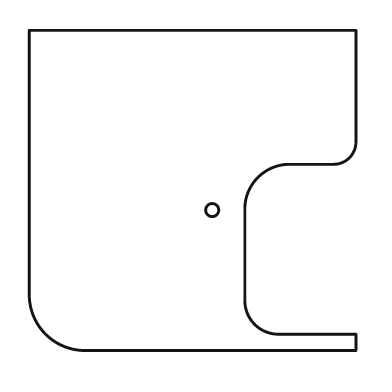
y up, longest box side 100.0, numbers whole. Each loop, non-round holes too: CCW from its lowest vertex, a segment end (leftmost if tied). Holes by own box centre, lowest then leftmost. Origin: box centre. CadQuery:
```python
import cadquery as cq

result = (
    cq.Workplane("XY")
    .moveTo(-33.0, -49.0)
    .lineTo(50.0, -49.0)
    .lineTo(50.0, -44.0)
    .lineTo(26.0, -44.0)
    .threePointArc((19.0, -41.0), (16.0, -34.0))
    .lineTo(16.0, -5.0)
    .threePointArc((20.0, 4.0), (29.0, 8.0))
    .lineTo(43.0, 8.0)
    .threePointArc((48.0, 10.0), (50.0, 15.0))
    .lineTo(50.0, 49.0)
    .lineTo(-50.0, 49.0)
    .lineTo(-50.0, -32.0)
    .threePointArc((-45.0, -44.0), (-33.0, -49.0))
    .close()
    .moveTo(6.0, -6.0)
    .circle(2.0)
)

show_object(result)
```